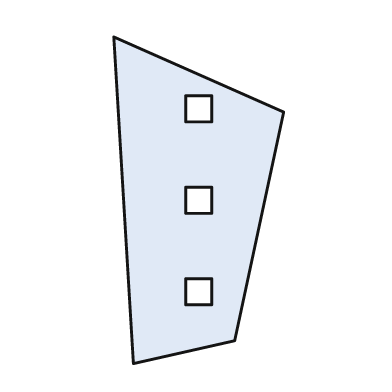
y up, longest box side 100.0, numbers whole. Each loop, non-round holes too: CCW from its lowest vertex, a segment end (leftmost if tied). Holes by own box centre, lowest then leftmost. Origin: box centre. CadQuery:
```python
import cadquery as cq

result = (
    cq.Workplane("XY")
    .moveTo(-20.0, -50.0)
    .lineTo(11.0, -43.0)
    .lineTo(26.0, 27.0)
    .lineTo(-26.0, 50.0)
    .close()
    .moveTo(-4.0, -32.0)
    .lineTo(4.0, -32.0)
    .lineTo(4.0, -24.0)
    .lineTo(-4.0, -24.0)
    .close()
    .moveTo(-4.0, -4.0)
    .lineTo(4.0, -4.0)
    .lineTo(4.0, 4.0)
    .lineTo(-4.0, 4.0)
    .close()
    .moveTo(-4.0, 24.0)
    .lineTo(4.0, 24.0)
    .lineTo(4.0, 32.0)
    .lineTo(-4.0, 32.0)
    .close()
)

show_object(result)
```